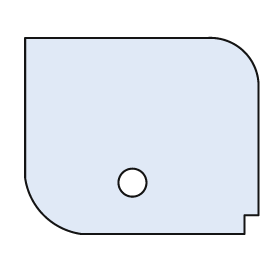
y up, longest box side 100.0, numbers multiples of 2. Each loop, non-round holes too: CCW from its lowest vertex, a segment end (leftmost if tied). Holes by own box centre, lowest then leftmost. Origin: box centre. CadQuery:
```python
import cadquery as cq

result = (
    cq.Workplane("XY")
    .moveTo(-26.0, -42.0)
    .lineTo(44.0, -42.0)
    .lineTo(44.0, -34.0)
    .lineTo(50.0, -34.0)
    .lineTo(50.0, 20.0)
    .threePointArc((44.0, 36.0), (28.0, 42.0))
    .lineTo(-50.0, 42.0)
    .lineTo(-50.0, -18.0)
    .threePointArc((-42.0, -34.0), (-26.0, -42.0))
    .close()
    .moveTo(-4.0, -20.0)
    .circle(6.0)
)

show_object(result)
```